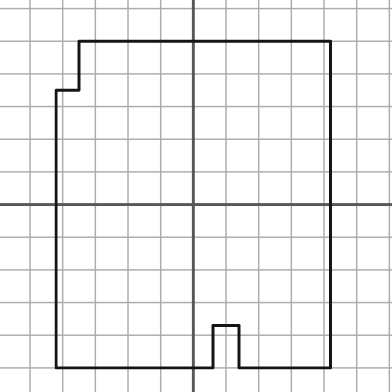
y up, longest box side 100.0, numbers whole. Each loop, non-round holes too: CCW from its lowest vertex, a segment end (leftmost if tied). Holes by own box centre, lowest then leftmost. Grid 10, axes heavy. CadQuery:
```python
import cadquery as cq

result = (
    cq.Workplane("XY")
    .moveTo(-42.0, -50.0)
    .lineTo(6.0, -50.0)
    .lineTo(6.0, -37.0)
    .lineTo(14.0, -37.0)
    .lineTo(14.0, -50.0)
    .lineTo(42.0, -50.0)
    .lineTo(42.0, 50.0)
    .lineTo(-35.0, 50.0)
    .lineTo(-35.0, 35.0)
    .lineTo(-42.0, 35.0)
    .close()
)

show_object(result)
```